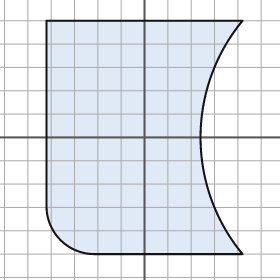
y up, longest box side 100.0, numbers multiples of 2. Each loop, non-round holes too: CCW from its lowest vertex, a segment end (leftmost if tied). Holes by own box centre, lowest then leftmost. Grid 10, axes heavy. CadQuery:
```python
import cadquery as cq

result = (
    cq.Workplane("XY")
    .moveTo(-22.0, -50.0)
    .lineTo(42.0, -50.0)
    .threePointArc((24.0, 0.0), (42.0, 50.0))
    .lineTo(-42.0, 50.0)
    .lineTo(-42.0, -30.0)
    .threePointArc((-36.0, -44.0), (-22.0, -50.0))
    .close()
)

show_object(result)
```